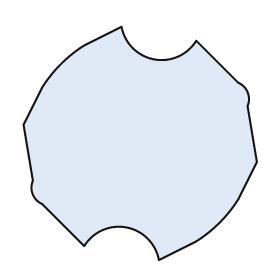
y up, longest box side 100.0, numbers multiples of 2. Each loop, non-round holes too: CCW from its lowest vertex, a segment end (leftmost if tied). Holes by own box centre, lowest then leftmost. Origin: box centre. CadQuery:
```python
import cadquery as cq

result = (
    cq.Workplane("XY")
    .moveTo(8.0, -50.0)
    .lineTo(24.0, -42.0)
    .threePointArc((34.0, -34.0), (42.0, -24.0))
    .lineTo(50.0, -8.0)
    .lineTo(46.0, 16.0)
    .threePointArc((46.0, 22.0), (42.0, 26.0))
    .lineTo(24.0, 44.0)
    .threePointArc((6.0, 36.0), (-8.0, 50.0))
    .lineTo(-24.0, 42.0)
    .threePointArc((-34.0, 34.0), (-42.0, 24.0))
    .lineTo(-50.0, 8.0)
    .lineTo(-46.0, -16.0)
    .threePointArc((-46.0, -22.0), (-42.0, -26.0))
    .lineTo(-24.0, -44.0)
    .threePointArc((-6.0, -36.0), (8.0, -50.0))
    .close()
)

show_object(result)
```